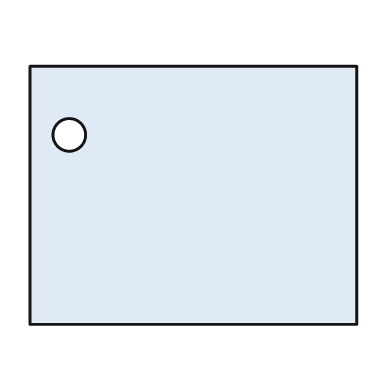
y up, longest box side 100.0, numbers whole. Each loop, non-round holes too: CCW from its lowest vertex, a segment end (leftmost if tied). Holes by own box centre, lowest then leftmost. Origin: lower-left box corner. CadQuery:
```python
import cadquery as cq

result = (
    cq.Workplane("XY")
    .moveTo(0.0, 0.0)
    .lineTo(100.0, 0.0)
    .lineTo(100.0, 79.0)
    .lineTo(0.0, 79.0)
    .close()
    .moveTo(12.0, 58.0)
    .circle(5.0)
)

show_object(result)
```